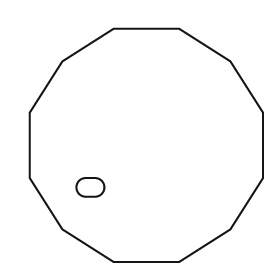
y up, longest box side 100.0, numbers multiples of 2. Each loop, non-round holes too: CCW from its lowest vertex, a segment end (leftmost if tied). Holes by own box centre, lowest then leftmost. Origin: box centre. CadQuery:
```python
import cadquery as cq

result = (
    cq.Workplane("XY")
    .moveTo(-14.0, -50.0)
    .lineTo(14.0, -50.0)
    .lineTo(36.0, -36.0)
    .lineTo(50.0, -14.0)
    .lineTo(50.0, 14.0)
    .lineTo(36.0, 36.0)
    .lineTo(14.0, 50.0)
    .lineTo(-14.0, 50.0)
    .lineTo(-36.0, 36.0)
    .lineTo(-50.0, 14.0)
    .lineTo(-50.0, -14.0)
    .lineTo(-36.0, -36.0)
    .close()
    .moveTo(-26.0, -22.0)
    .lineTo(-22.0, -22.0)
    .threePointArc((-18.0, -18.0), (-22.0, -14.0))
    .lineTo(-26.0, -14.0)
    .threePointArc((-30.0, -18.0), (-26.0, -22.0))
    .close()
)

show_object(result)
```